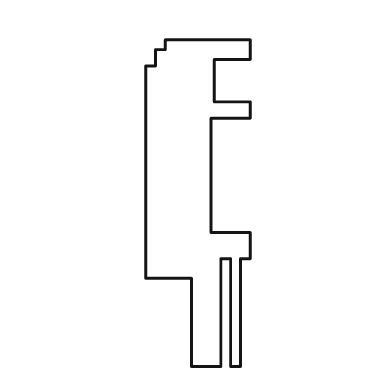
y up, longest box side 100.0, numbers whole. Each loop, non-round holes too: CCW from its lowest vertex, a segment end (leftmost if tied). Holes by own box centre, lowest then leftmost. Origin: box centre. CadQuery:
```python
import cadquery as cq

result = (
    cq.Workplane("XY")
    .moveTo(-2.0, -50.0)
    .lineTo(7.0, -50.0)
    .lineTo(7.0, -17.0)
    .lineTo(10.0, -17.0)
    .lineTo(10.0, -50.0)
    .lineTo(13.0, -50.0)
    .lineTo(13.0, -17.0)
    .lineTo(16.0, -17.0)
    .lineTo(16.0, -9.0)
    .lineTo(4.0, -9.0)
    .lineTo(4.0, 26.0)
    .lineTo(16.0, 26.0)
    .lineTo(16.0, 31.0)
    .lineTo(5.0, 31.0)
    .lineTo(5.0, 44.0)
    .lineTo(16.0, 44.0)
    .lineTo(16.0, 50.0)
    .lineTo(-10.0, 50.0)
    .lineTo(-10.0, 47.0)
    .lineTo(-13.0, 47.0)
    .lineTo(-13.0, 42.0)
    .lineTo(-16.0, 42.0)
    .lineTo(-16.0, -23.0)
    .lineTo(-2.0, -23.0)
    .close()
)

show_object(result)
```